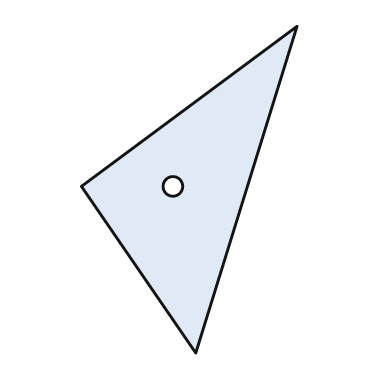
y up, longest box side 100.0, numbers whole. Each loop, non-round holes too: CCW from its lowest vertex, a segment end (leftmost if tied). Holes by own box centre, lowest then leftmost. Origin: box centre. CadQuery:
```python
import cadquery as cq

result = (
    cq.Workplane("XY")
    .moveTo(2.0, -50.0)
    .lineTo(33.0, 50.0)
    .lineTo(-33.0, 1.0)
    .close()
    .moveTo(-5.0, 1.0)
    .circle(3.0)
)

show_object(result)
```